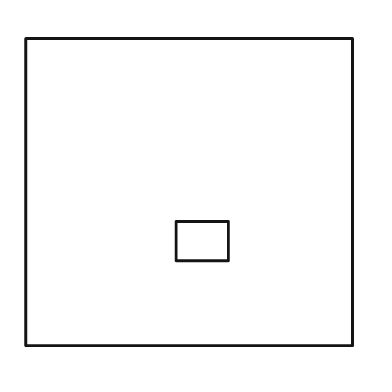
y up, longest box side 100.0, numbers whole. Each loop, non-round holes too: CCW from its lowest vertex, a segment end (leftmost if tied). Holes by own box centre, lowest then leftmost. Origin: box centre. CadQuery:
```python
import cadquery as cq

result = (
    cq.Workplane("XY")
    .moveTo(-50.0, -47.0)
    .lineTo(50.0, -47.0)
    .lineTo(50.0, 47.0)
    .lineTo(-50.0, 47.0)
    .close()
    .moveTo(-4.0, -21.0)
    .lineTo(12.0, -21.0)
    .lineTo(12.0, -9.0)
    .lineTo(-4.0, -9.0)
    .close()
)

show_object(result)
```